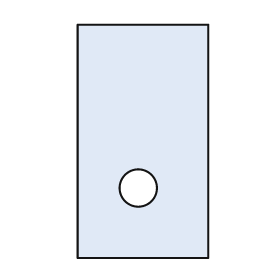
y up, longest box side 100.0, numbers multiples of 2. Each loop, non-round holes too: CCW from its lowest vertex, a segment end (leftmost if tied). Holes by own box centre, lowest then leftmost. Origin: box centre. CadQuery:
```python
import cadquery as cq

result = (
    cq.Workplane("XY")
    .moveTo(-28.0, -50.0)
    .lineTo(28.0, -50.0)
    .lineTo(28.0, 50.0)
    .lineTo(-28.0, 50.0)
    .close()
    .moveTo(-2.0, -20.0)
    .circle(8.0)
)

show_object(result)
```